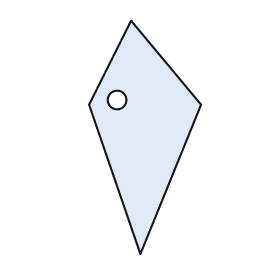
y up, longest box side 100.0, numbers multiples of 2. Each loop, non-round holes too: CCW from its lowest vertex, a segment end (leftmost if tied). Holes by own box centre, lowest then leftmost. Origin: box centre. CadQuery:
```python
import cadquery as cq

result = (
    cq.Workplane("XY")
    .moveTo(-2.0, -50.0)
    .lineTo(24.0, 14.0)
    .lineTo(-6.0, 50.0)
    .lineTo(-24.0, 14.0)
    .close()
    .moveTo(-12.0, 16.0)
    .circle(4.0)
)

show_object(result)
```